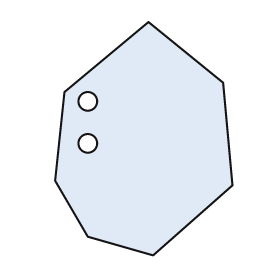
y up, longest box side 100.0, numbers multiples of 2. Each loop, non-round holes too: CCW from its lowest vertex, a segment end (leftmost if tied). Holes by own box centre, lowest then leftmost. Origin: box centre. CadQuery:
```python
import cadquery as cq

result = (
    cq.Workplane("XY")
    .moveTo(4.0, -50.0)
    .lineTo(38.0, -20.0)
    .lineTo(34.0, 24.0)
    .lineTo(2.0, 50.0)
    .lineTo(-34.0, 20.0)
    .lineTo(-38.0, -18.0)
    .lineTo(-24.0, -42.0)
    .close()
    .moveTo(-24.0, -2.0)
    .circle(4.0)
    .moveTo(-24.0, 16.0)
    .circle(4.0)
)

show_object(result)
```